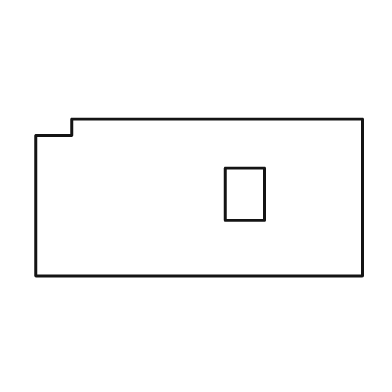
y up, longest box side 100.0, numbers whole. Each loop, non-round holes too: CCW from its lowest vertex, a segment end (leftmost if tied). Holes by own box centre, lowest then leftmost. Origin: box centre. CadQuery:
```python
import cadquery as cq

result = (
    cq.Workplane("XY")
    .moveTo(-50.0, -24.0)
    .lineTo(50.0, -24.0)
    .lineTo(50.0, 24.0)
    .lineTo(-39.0, 24.0)
    .lineTo(-39.0, 19.0)
    .lineTo(-50.0, 19.0)
    .close()
    .moveTo(8.0, -7.0)
    .lineTo(20.0, -7.0)
    .lineTo(20.0, 9.0)
    .lineTo(8.0, 9.0)
    .close()
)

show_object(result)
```